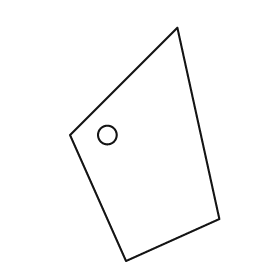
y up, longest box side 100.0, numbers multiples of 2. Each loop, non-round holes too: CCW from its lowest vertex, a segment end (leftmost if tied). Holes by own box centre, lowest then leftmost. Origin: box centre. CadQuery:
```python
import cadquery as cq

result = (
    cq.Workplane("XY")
    .moveTo(-8.0, -50.0)
    .lineTo(32.0, -32.0)
    .lineTo(14.0, 50.0)
    .lineTo(-32.0, 4.0)
    .close()
    .moveTo(-16.0, 4.0)
    .circle(4.0)
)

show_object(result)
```